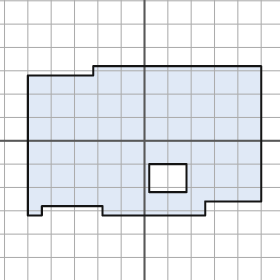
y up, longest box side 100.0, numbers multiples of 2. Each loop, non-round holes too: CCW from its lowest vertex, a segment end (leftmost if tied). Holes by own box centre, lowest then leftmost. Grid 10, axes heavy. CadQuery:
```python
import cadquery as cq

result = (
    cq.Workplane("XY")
    .moveTo(-50.0, -32.0)
    .lineTo(-44.0, -32.0)
    .lineTo(-44.0, -28.0)
    .lineTo(-18.0, -28.0)
    .lineTo(-18.0, -32.0)
    .lineTo(26.0, -32.0)
    .lineTo(26.0, -26.0)
    .lineTo(50.0, -26.0)
    .lineTo(50.0, 32.0)
    .lineTo(-22.0, 32.0)
    .lineTo(-22.0, 28.0)
    .lineTo(-50.0, 28.0)
    .close()
    .moveTo(2.0, -22.0)
    .lineTo(18.0, -22.0)
    .lineTo(18.0, -10.0)
    .lineTo(2.0, -10.0)
    .close()
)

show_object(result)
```